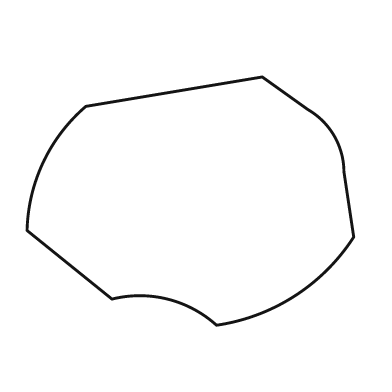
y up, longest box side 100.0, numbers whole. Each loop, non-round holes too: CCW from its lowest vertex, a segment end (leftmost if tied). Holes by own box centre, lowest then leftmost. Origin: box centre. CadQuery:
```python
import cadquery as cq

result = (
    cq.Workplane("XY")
    .moveTo(8.0, -38.0)
    .threePointArc((32.0, -29.0), (50.0, -11.0))
    .lineTo(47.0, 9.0)
    .threePointArc((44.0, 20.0), (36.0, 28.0))
    .lineTo(22.0, 38.0)
    .lineTo(-32.0, 29.0)
    .threePointArc((-45.0, 12.0), (-50.0, -9.0))
    .lineTo(-24.0, -30.0)
    .threePointArc((-7.0, -30.0), (8.0, -38.0))
    .close()
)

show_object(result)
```